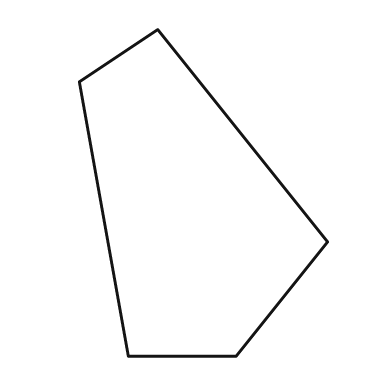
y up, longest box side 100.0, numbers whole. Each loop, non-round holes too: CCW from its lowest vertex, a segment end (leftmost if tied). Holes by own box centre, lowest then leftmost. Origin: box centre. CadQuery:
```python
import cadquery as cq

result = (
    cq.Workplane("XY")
    .moveTo(-23.0, -50.0)
    .lineTo(10.0, -50.0)
    .lineTo(38.0, -15.0)
    .lineTo(-14.0, 50.0)
    .lineTo(-38.0, 34.0)
    .close()
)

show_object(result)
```